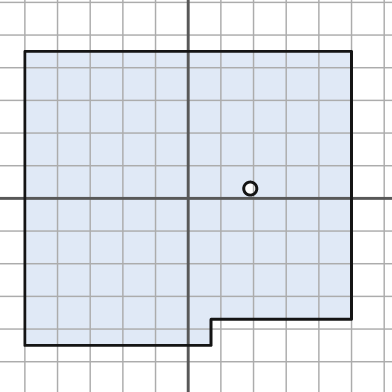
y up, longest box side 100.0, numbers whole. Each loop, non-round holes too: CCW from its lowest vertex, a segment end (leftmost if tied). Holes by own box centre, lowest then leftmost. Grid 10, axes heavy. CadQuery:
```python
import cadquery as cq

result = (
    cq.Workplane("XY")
    .moveTo(-50.0, -45.0)
    .lineTo(7.0, -45.0)
    .lineTo(7.0, -37.0)
    .lineTo(50.0, -37.0)
    .lineTo(50.0, 45.0)
    .lineTo(-50.0, 45.0)
    .close()
    .moveTo(19.0, 3.0)
    .circle(2.0)
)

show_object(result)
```